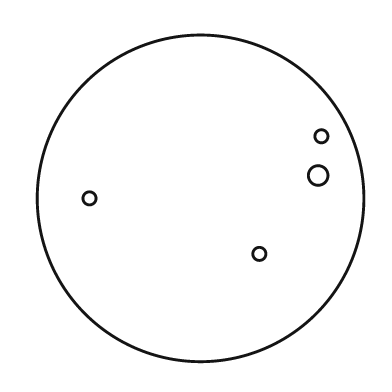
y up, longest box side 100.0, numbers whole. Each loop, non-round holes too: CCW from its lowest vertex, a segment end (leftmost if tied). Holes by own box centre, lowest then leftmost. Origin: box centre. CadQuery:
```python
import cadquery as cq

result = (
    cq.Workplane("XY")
    .moveTo(0.0, 0.0)
    .circle(50.0)
    .moveTo(18.0, -17.0)
    .circle(2.0)
    .moveTo(-34.0, 0.0)
    .circle(2.0)
    .moveTo(36.0, 7.0)
    .circle(3.0)
    .moveTo(37.0, 19.0)
    .circle(2.0)
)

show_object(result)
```